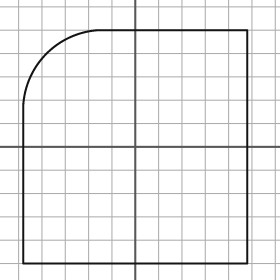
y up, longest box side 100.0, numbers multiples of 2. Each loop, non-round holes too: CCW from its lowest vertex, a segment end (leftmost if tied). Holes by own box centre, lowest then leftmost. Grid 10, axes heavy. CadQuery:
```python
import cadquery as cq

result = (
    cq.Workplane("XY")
    .moveTo(-48.0, -50.0)
    .lineTo(48.0, -50.0)
    .lineTo(48.0, 50.0)
    .lineTo(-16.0, 50.0)
    .threePointArc((-38.0, 40.0), (-48.0, 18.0))
    .close()
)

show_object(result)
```